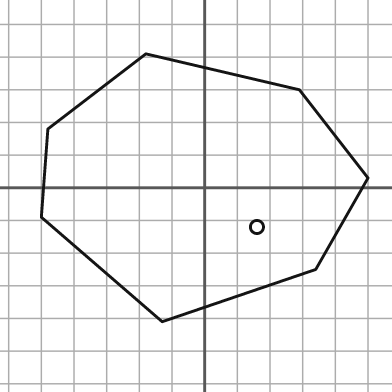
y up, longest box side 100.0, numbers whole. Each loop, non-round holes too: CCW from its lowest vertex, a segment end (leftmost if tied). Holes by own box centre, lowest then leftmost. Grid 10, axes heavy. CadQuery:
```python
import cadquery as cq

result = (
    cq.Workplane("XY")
    .moveTo(-13.0, -41.0)
    .lineTo(34.0, -25.0)
    .lineTo(50.0, 3.0)
    .lineTo(29.0, 30.0)
    .lineTo(-18.0, 41.0)
    .lineTo(-48.0, 18.0)
    .lineTo(-50.0, -9.0)
    .close()
    .moveTo(16.0, -12.0)
    .circle(2.0)
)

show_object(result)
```